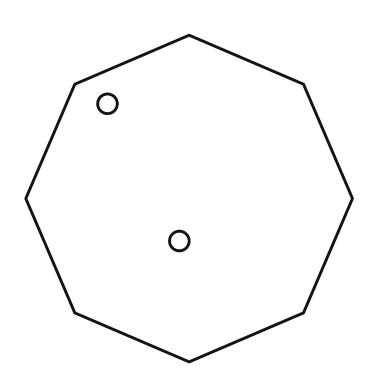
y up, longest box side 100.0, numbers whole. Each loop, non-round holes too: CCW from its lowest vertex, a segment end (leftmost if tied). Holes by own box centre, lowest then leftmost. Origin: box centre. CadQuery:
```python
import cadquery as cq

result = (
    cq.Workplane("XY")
    .moveTo(0.0, -50.0)
    .lineTo(35.0, -35.0)
    .lineTo(50.0, 0.0)
    .lineTo(35.0, 35.0)
    .lineTo(0.0, 50.0)
    .lineTo(-35.0, 35.0)
    .lineTo(-50.0, 0.0)
    .lineTo(-35.0, -35.0)
    .close()
    .moveTo(-3.0, -13.0)
    .circle(3.0)
    .moveTo(-25.0, 29.0)
    .circle(3.0)
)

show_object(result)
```